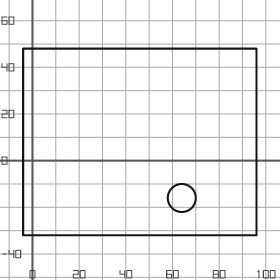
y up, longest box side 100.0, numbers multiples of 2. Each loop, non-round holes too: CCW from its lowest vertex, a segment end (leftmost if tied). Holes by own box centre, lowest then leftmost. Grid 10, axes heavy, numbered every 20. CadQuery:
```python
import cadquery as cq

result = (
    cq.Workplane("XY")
    .moveTo(-4.0, -32.0)
    .lineTo(96.0, -32.0)
    .lineTo(96.0, 48.0)
    .lineTo(-4.0, 48.0)
    .close()
    .moveTo(64.0, -16.0)
    .circle(6.0)
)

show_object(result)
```